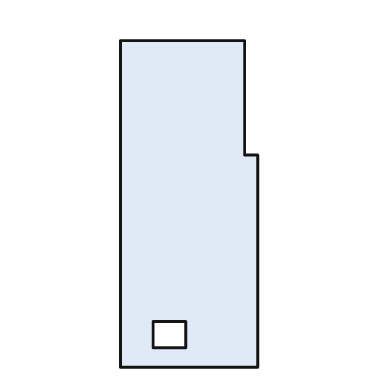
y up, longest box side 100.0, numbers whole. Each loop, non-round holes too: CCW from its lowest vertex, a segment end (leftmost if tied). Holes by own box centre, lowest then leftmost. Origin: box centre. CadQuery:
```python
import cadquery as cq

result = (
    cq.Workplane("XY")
    .moveTo(-21.0, -50.0)
    .lineTo(21.0, -50.0)
    .lineTo(21.0, 15.0)
    .lineTo(17.0, 15.0)
    .lineTo(17.0, 50.0)
    .lineTo(-21.0, 50.0)
    .close()
    .moveTo(-11.0, -44.0)
    .lineTo(-1.0, -44.0)
    .lineTo(-1.0, -36.0)
    .lineTo(-11.0, -36.0)
    .close()
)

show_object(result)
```